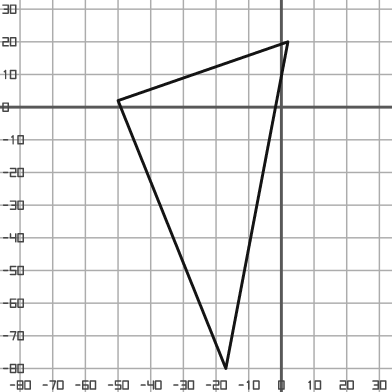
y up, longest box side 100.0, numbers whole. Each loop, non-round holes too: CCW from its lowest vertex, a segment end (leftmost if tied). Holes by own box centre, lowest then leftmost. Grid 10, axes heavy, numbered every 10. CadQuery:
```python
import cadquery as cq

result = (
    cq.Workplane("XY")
    .moveTo(-17.0, -80.0)
    .lineTo(2.0, 20.0)
    .lineTo(-50.0, 2.0)
    .close()
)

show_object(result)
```